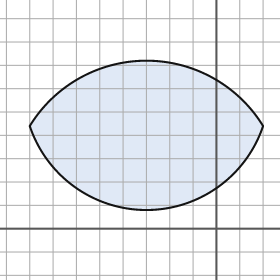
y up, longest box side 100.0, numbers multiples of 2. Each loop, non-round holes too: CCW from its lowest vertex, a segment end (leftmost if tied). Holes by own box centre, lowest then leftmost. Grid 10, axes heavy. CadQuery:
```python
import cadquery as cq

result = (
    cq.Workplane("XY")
    .moveTo(-80.0, 44.0)
    .threePointArc((-30.0, 8.0), (20.0, 44.0))
    .threePointArc((-30.0, 72.0), (-80.0, 44.0))
    .close()
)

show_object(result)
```